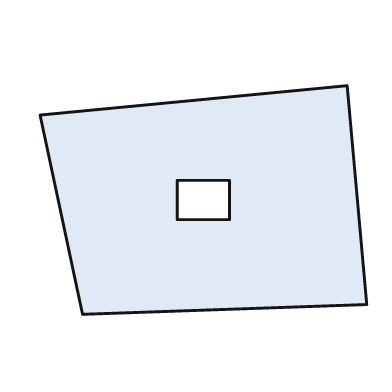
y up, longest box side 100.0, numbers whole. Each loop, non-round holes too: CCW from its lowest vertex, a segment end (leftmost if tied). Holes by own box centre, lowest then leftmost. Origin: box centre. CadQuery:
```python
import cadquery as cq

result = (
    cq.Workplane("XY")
    .moveTo(-37.0, -35.0)
    .lineTo(50.0, -32.0)
    .lineTo(44.0, 35.0)
    .lineTo(-50.0, 26.0)
    .close()
    .moveTo(-8.0, -6.0)
    .lineTo(8.0, -6.0)
    .lineTo(8.0, 6.0)
    .lineTo(-8.0, 6.0)
    .close()
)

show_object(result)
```